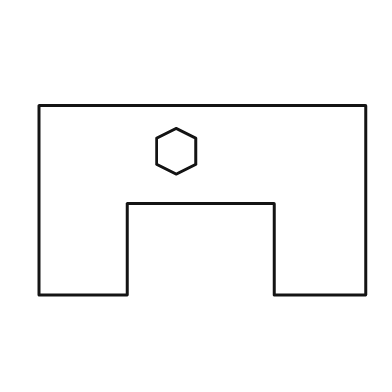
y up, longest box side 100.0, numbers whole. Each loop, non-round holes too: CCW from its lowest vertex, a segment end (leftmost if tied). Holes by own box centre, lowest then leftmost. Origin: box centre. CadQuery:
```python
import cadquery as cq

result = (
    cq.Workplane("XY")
    .moveTo(-50.0, -29.0)
    .lineTo(-23.0, -29.0)
    .lineTo(-23.0, -1.0)
    .lineTo(22.0, -1.0)
    .lineTo(22.0, -29.0)
    .lineTo(50.0, -29.0)
    .lineTo(50.0, 29.0)
    .lineTo(-50.0, 29.0)
    .close()
    .moveTo(-8.0, 8.0)
    .lineTo(-2.0, 11.0)
    .lineTo(-2.0, 19.0)
    .lineTo(-8.0, 22.0)
    .lineTo(-14.0, 19.0)
    .lineTo(-14.0, 11.0)
    .close()
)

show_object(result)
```